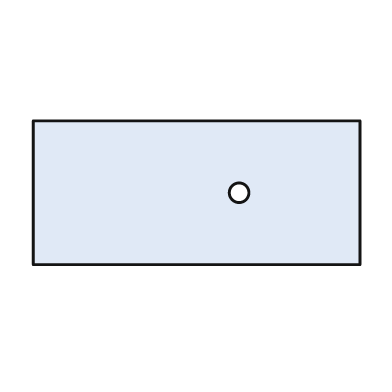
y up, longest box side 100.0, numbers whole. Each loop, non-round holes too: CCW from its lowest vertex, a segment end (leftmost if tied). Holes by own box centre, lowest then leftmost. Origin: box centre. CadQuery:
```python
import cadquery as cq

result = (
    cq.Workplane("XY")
    .moveTo(-50.0, -22.0)
    .lineTo(50.0, -22.0)
    .lineTo(50.0, 22.0)
    .lineTo(-50.0, 22.0)
    .close()
    .moveTo(13.0, 0.0)
    .circle(3.0)
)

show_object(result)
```